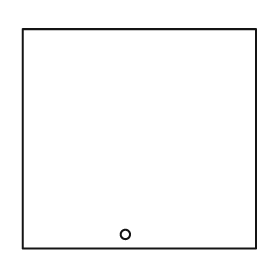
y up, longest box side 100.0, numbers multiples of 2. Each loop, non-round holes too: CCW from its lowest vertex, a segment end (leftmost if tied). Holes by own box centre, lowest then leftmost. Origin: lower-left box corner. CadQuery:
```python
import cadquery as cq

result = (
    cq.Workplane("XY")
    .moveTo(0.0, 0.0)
    .lineTo(100.0, 0.0)
    .lineTo(100.0, 94.0)
    .lineTo(0.0, 94.0)
    .close()
    .moveTo(44.0, 6.0)
    .circle(2.0)
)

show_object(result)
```